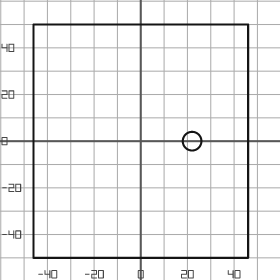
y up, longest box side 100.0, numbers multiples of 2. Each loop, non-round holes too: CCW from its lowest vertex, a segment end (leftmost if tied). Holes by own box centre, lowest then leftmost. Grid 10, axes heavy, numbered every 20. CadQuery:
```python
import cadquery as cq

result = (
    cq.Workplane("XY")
    .moveTo(-46.0, -50.0)
    .lineTo(46.0, -50.0)
    .lineTo(46.0, 50.0)
    .lineTo(-46.0, 50.0)
    .close()
    .moveTo(22.0, 0.0)
    .circle(4.0)
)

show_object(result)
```